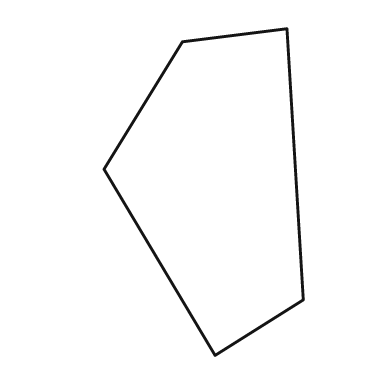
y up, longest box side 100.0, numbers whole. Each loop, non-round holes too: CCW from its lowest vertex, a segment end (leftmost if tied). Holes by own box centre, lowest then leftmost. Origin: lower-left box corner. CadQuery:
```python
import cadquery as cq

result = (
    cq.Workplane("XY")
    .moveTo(34.0, 0.0)
    .lineTo(61.0, 17.0)
    .lineTo(56.0, 100.0)
    .lineTo(24.0, 96.0)
    .lineTo(0.0, 57.0)
    .close()
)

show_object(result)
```